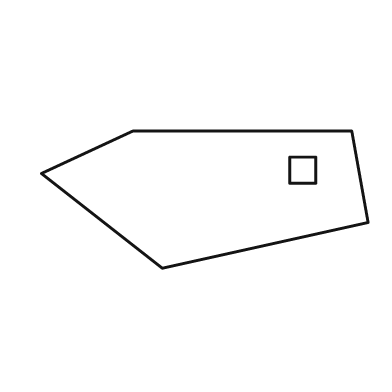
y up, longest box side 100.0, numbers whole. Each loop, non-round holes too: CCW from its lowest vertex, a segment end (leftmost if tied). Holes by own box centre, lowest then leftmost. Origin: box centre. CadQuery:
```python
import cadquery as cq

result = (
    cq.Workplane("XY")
    .moveTo(-13.0, -21.0)
    .lineTo(50.0, -7.0)
    .lineTo(45.0, 21.0)
    .lineTo(-22.0, 21.0)
    .lineTo(-50.0, 8.0)
    .close()
    .moveTo(26.0, 5.0)
    .lineTo(34.0, 5.0)
    .lineTo(34.0, 13.0)
    .lineTo(26.0, 13.0)
    .close()
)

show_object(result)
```